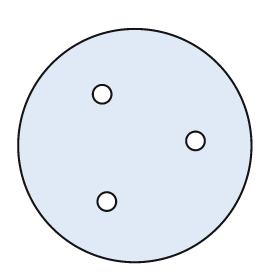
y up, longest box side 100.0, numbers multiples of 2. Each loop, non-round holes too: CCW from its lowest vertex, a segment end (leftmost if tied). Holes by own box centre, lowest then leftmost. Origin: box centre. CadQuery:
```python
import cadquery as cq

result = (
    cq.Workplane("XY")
    .moveTo(0.0, 0.0)
    .circle(50.0)
    .moveTo(-12.0, -24.0)
    .circle(4.0)
    .moveTo(26.0, 2.0)
    .circle(4.0)
    .moveTo(-14.0, 22.0)
    .circle(4.0)
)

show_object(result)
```